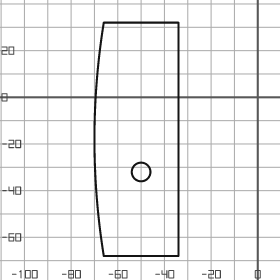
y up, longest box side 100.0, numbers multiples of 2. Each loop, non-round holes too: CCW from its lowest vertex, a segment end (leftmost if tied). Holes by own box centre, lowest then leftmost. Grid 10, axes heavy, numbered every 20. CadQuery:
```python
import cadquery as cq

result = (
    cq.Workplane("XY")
    .moveTo(-66.0, -68.0)
    .lineTo(-34.0, -68.0)
    .lineTo(-34.0, 32.0)
    .lineTo(-66.0, 32.0)
    .threePointArc((-70.0, -18.0), (-66.0, -68.0))
    .close()
    .moveTo(-50.0, -32.0)
    .circle(4.0)
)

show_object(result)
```